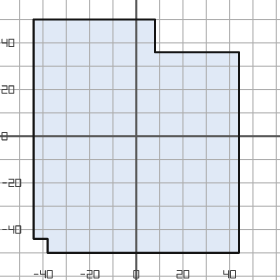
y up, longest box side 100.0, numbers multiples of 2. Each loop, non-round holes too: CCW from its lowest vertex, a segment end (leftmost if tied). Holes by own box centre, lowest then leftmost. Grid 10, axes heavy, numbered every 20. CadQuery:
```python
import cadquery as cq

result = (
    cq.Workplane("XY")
    .moveTo(-38.0, -50.0)
    .lineTo(44.0, -50.0)
    .lineTo(44.0, 36.0)
    .lineTo(8.0, 36.0)
    .lineTo(8.0, 50.0)
    .lineTo(-44.0, 50.0)
    .lineTo(-44.0, -44.0)
    .lineTo(-38.0, -44.0)
    .close()
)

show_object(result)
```